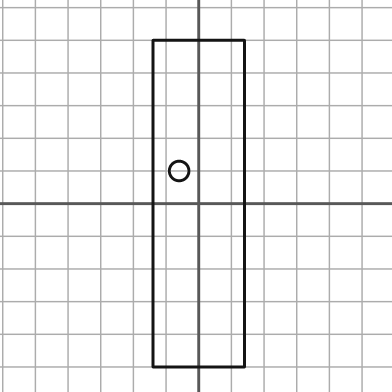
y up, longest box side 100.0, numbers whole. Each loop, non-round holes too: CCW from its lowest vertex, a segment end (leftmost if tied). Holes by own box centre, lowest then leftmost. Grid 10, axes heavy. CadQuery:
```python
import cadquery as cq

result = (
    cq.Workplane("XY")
    .moveTo(-14.0, -50.0)
    .lineTo(14.0, -50.0)
    .lineTo(14.0, 50.0)
    .lineTo(-14.0, 50.0)
    .close()
    .moveTo(-6.0, 10.0)
    .circle(3.0)
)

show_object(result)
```